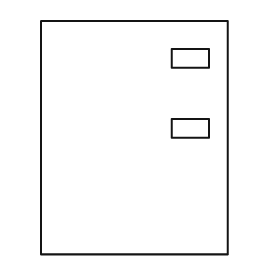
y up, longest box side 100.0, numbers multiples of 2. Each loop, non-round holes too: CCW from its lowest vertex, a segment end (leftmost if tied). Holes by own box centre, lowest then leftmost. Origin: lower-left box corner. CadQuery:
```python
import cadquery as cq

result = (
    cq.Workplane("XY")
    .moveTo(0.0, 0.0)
    .lineTo(80.0, 0.0)
    .lineTo(80.0, 100.0)
    .lineTo(0.0, 100.0)
    .close()
    .moveTo(56.0, 50.0)
    .lineTo(72.0, 50.0)
    .lineTo(72.0, 58.0)
    .lineTo(56.0, 58.0)
    .close()
    .moveTo(56.0, 80.0)
    .lineTo(72.0, 80.0)
    .lineTo(72.0, 88.0)
    .lineTo(56.0, 88.0)
    .close()
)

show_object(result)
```